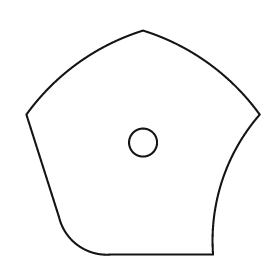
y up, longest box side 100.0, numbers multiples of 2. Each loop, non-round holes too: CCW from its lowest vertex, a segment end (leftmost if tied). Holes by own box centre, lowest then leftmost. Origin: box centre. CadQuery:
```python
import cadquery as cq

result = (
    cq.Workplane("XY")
    .moveTo(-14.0, -48.0)
    .lineTo(30.0, -48.0)
    .threePointArc((34.0, -16.0), (50.0, 12.0))
    .threePointArc((28.0, 34.0), (0.0, 48.0))
    .threePointArc((-28.0, 34.0), (-50.0, 12.0))
    .lineTo(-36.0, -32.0)
    .threePointArc((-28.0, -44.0), (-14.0, -48.0))
    .close()
    .moveTo(0.0, 0.0)
    .circle(6.0)
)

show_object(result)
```